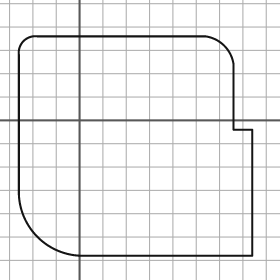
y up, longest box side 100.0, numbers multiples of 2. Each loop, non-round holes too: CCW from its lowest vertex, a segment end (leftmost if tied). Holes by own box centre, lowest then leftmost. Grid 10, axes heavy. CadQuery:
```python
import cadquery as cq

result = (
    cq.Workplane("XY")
    .moveTo(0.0, -58.0)
    .lineTo(74.0, -58.0)
    .lineTo(74.0, -4.0)
    .lineTo(66.0, -4.0)
    .lineTo(66.0, 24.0)
    .threePointArc((62.0, 32.0), (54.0, 36.0))
    .lineTo(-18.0, 36.0)
    .threePointArc((-24.0, 34.0), (-26.0, 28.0))
    .lineTo(-26.0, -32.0)
    .threePointArc((-18.0, -50.0), (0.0, -58.0))
    .close()
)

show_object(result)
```